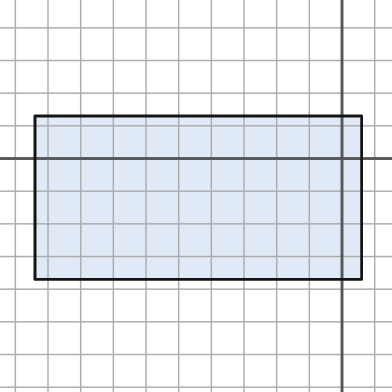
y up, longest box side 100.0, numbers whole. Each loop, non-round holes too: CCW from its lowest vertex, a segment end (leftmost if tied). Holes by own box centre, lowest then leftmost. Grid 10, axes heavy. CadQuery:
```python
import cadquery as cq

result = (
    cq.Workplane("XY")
    .moveTo(-94.0, -37.0)
    .lineTo(6.0, -37.0)
    .lineTo(6.0, 13.0)
    .lineTo(-94.0, 13.0)
    .close()
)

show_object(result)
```